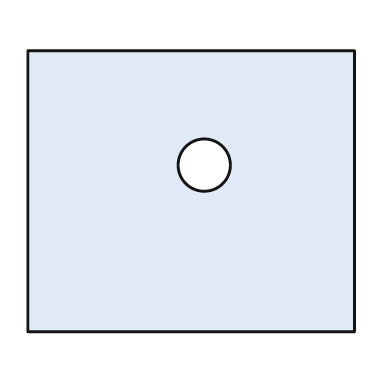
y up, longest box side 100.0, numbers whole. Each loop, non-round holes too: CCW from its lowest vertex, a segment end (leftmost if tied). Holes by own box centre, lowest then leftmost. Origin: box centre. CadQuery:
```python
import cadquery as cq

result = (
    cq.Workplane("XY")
    .moveTo(-50.0, -43.0)
    .lineTo(50.0, -43.0)
    .lineTo(50.0, 43.0)
    .lineTo(-50.0, 43.0)
    .close()
    .moveTo(4.0, 8.0)
    .circle(8.0)
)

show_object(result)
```